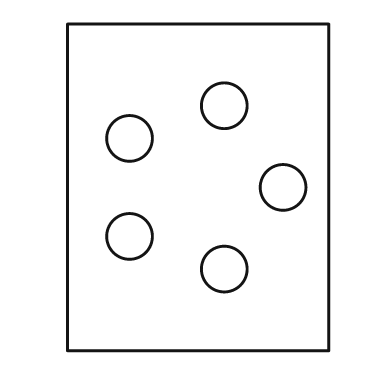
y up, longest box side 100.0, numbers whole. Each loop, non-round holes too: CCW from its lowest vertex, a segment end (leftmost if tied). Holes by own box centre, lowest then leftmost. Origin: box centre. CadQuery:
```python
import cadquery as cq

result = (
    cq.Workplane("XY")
    .moveTo(-40.0, -50.0)
    .lineTo(40.0, -50.0)
    .lineTo(40.0, 50.0)
    .lineTo(-40.0, 50.0)
    .close()
    .moveTo(8.0, -25.0)
    .circle(7.0)
    .moveTo(-21.0, -15.0)
    .circle(7.0)
    .moveTo(26.0, 0.0)
    .circle(7.0)
    .moveTo(-21.0, 15.0)
    .circle(7.0)
    .moveTo(8.0, 25.0)
    .circle(7.0)
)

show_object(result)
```